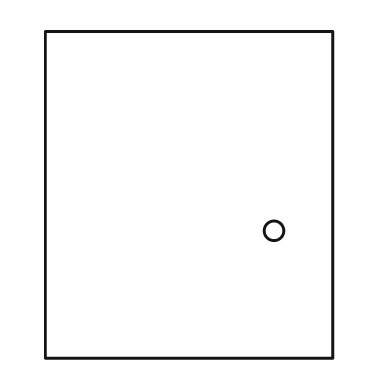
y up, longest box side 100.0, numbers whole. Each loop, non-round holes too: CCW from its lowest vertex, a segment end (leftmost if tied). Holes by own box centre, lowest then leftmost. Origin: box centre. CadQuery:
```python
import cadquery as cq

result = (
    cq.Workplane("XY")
    .moveTo(-44.0, -50.0)
    .lineTo(44.0, -50.0)
    .lineTo(44.0, 50.0)
    .lineTo(-44.0, 50.0)
    .close()
    .moveTo(26.0, -11.0)
    .circle(3.0)
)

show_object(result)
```